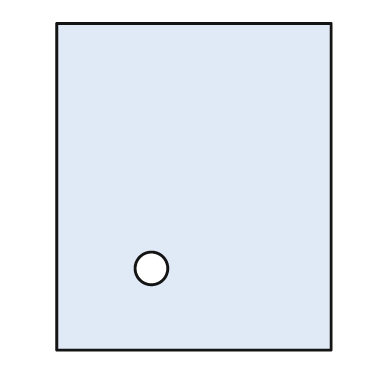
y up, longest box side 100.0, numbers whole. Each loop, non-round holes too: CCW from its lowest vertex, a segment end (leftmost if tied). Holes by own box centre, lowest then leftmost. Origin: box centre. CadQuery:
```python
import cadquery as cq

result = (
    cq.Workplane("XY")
    .moveTo(-42.0, -50.0)
    .lineTo(42.0, -50.0)
    .lineTo(42.0, 50.0)
    .lineTo(-42.0, 50.0)
    .close()
    .moveTo(-13.0, -25.0)
    .circle(5.0)
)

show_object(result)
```